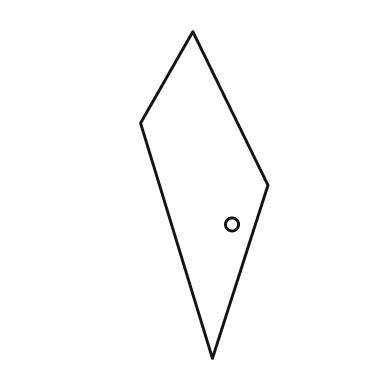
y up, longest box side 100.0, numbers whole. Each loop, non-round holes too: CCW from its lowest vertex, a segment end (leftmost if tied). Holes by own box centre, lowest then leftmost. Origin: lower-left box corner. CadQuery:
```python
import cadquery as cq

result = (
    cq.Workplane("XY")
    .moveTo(22.0, 0.0)
    .lineTo(39.0, 53.0)
    .lineTo(16.0, 100.0)
    .lineTo(0.0, 72.0)
    .close()
    .moveTo(28.0, 41.0)
    .circle(2.0)
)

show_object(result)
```